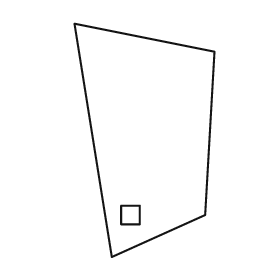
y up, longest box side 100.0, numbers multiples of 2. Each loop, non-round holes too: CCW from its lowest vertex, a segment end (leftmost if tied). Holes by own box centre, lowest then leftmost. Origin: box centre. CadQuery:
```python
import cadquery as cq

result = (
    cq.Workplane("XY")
    .moveTo(-14.0, -50.0)
    .lineTo(26.0, -32.0)
    .lineTo(30.0, 38.0)
    .lineTo(-30.0, 50.0)
    .close()
    .moveTo(-10.0, -36.0)
    .lineTo(-2.0, -36.0)
    .lineTo(-2.0, -28.0)
    .lineTo(-10.0, -28.0)
    .close()
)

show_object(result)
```